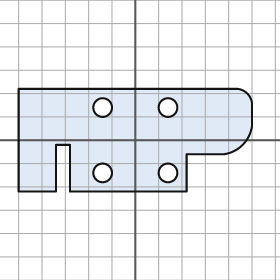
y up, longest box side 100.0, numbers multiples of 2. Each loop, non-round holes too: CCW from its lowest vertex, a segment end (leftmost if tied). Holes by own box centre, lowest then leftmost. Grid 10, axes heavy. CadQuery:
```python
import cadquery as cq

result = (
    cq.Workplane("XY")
    .moveTo(-50.0, -22.0)
    .lineTo(-34.0, -22.0)
    .lineTo(-34.0, -2.0)
    .lineTo(-28.0, -2.0)
    .lineTo(-28.0, -22.0)
    .lineTo(22.0, -22.0)
    .lineTo(22.0, -6.0)
    .lineTo(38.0, -6.0)
    .threePointArc((46.0, -2.0), (50.0, 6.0))
    .lineTo(50.0, 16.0)
    .threePointArc((48.0, 20.0), (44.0, 22.0))
    .lineTo(-50.0, 22.0)
    .close()
    .moveTo(-14.0, -14.0)
    .circle(4.0)
    .moveTo(14.0, -14.0)
    .circle(4.0)
    .moveTo(-14.0, 14.0)
    .circle(4.0)
    .moveTo(14.0, 14.0)
    .circle(4.0)
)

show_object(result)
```